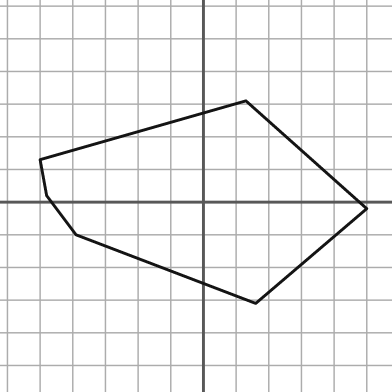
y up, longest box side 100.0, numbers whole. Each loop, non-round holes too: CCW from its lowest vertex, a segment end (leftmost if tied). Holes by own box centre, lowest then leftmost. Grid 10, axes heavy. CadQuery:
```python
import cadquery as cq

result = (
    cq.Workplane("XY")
    .moveTo(16.0, -31.0)
    .lineTo(50.0, -2.0)
    .lineTo(13.0, 31.0)
    .lineTo(-50.0, 13.0)
    .lineTo(-48.0, 2.0)
    .lineTo(-39.0, -10.0)
    .close()
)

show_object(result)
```